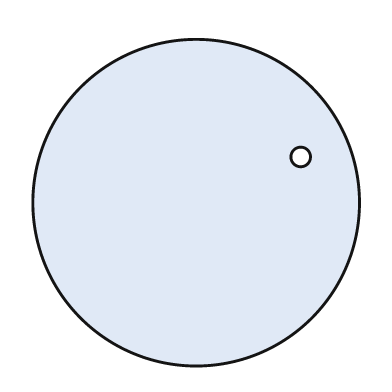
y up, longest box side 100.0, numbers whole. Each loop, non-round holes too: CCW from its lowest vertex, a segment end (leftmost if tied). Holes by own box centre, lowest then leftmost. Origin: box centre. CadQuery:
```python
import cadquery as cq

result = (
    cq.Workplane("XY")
    .moveTo(0.0, 0.0)
    .circle(50.0)
    .moveTo(32.0, 14.0)
    .circle(3.0)
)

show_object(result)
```